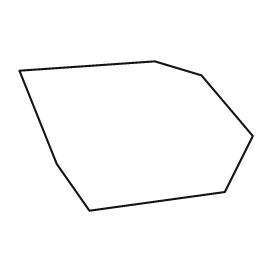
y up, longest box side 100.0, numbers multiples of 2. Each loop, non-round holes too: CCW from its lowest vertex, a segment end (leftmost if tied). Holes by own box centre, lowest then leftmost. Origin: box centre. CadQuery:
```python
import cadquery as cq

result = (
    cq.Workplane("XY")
    .moveTo(-20.0, -32.0)
    .lineTo(38.0, -24.0)
    .lineTo(50.0, 0.0)
    .lineTo(28.0, 26.0)
    .lineTo(8.0, 32.0)
    .lineTo(-50.0, 28.0)
    .lineTo(-34.0, -12.0)
    .close()
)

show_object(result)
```